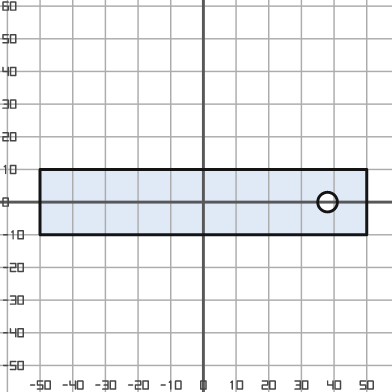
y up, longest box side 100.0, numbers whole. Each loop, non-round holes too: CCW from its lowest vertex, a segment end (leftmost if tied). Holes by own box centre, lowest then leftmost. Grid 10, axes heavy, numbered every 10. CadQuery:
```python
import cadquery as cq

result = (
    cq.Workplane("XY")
    .moveTo(-50.0, -10.0)
    .lineTo(50.0, -10.0)
    .lineTo(50.0, 10.0)
    .lineTo(-50.0, 10.0)
    .close()
    .moveTo(38.0, 0.0)
    .circle(3.0)
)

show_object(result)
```